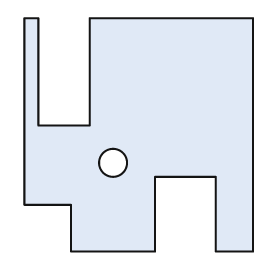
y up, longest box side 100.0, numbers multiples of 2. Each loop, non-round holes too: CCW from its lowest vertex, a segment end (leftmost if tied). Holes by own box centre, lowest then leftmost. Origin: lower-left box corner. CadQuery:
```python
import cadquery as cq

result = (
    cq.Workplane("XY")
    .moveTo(20.0, 0.0)
    .lineTo(56.0, 0.0)
    .lineTo(56.0, 32.0)
    .lineTo(82.0, 32.0)
    .lineTo(82.0, 0.0)
    .lineTo(98.0, 0.0)
    .lineTo(98.0, 100.0)
    .lineTo(28.0, 100.0)
    .lineTo(28.0, 54.0)
    .lineTo(6.0, 54.0)
    .lineTo(6.0, 100.0)
    .lineTo(0.0, 100.0)
    .lineTo(0.0, 20.0)
    .lineTo(20.0, 20.0)
    .close()
    .moveTo(38.0, 38.0)
    .circle(6.0)
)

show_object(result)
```